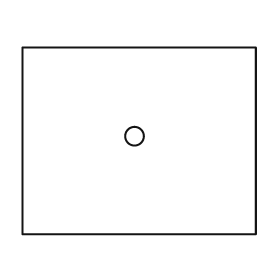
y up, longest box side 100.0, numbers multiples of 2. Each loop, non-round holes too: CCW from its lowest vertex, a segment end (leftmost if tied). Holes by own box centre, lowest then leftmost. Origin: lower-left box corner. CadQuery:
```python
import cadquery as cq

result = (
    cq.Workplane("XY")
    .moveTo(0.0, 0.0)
    .lineTo(100.0, 0.0)
    .lineTo(100.0, 80.0)
    .lineTo(0.0, 80.0)
    .close()
    .moveTo(48.0, 42.0)
    .circle(4.0)
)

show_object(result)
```